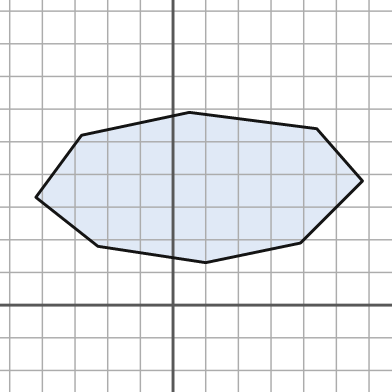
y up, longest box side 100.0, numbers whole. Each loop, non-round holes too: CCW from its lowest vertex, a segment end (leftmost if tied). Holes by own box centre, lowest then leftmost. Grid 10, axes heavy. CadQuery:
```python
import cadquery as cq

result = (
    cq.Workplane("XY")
    .moveTo(10.0, 13.0)
    .lineTo(39.0, 19.0)
    .lineTo(58.0, 38.0)
    .lineTo(44.0, 54.0)
    .lineTo(5.0, 59.0)
    .lineTo(-28.0, 52.0)
    .lineTo(-42.0, 33.0)
    .lineTo(-23.0, 18.0)
    .close()
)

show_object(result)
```